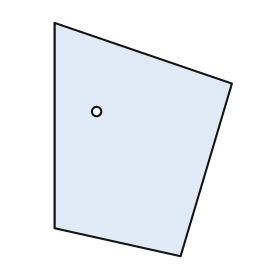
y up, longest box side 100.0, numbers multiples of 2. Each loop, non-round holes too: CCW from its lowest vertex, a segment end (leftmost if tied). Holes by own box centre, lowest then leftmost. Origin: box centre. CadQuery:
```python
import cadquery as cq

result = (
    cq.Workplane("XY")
    .moveTo(16.0, -50.0)
    .lineTo(38.0, 24.0)
    .lineTo(-38.0, 50.0)
    .lineTo(-38.0, -38.0)
    .close()
    .moveTo(-20.0, 12.0)
    .circle(2.0)
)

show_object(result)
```